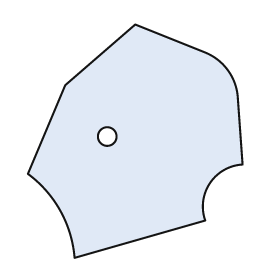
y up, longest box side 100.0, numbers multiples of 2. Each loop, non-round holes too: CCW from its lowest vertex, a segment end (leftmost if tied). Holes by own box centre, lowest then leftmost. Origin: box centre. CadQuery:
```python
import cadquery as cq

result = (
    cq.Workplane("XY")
    .moveTo(-26.0, -50.0)
    .lineTo(30.0, -34.0)
    .threePointArc((32.0, -18.0), (46.0, -10.0))
    .lineTo(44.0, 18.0)
    .threePointArc((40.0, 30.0), (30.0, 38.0))
    .lineTo(0.0, 50.0)
    .lineTo(-30.0, 24.0)
    .lineTo(-46.0, -14.0)
    .threePointArc((-32.0, -30.0), (-26.0, -50.0))
    .close()
    .moveTo(-12.0, 2.0)
    .circle(4.0)
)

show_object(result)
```